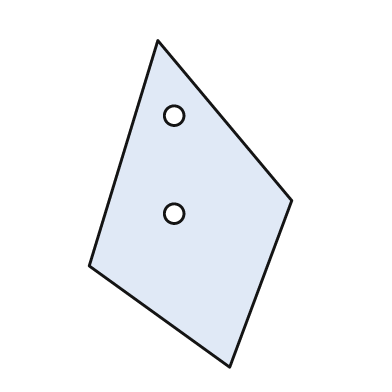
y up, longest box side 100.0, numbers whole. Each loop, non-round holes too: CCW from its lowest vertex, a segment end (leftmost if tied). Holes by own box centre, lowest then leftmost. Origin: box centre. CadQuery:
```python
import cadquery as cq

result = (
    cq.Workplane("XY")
    .moveTo(12.0, -50.0)
    .lineTo(31.0, 1.0)
    .lineTo(-10.0, 50.0)
    .lineTo(-31.0, -19.0)
    .close()
    .moveTo(-5.0, -3.0)
    .circle(3.0)
    .moveTo(-5.0, 27.0)
    .circle(3.0)
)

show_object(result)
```